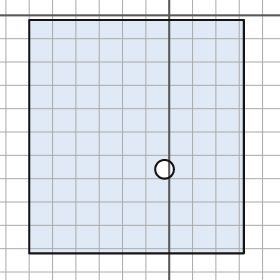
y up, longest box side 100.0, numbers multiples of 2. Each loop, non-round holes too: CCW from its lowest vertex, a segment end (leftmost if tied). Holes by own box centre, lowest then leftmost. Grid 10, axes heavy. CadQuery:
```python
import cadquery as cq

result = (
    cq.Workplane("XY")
    .moveTo(-60.0, -102.0)
    .lineTo(32.0, -102.0)
    .lineTo(32.0, -2.0)
    .lineTo(-60.0, -2.0)
    .close()
    .moveTo(-2.0, -66.0)
    .circle(4.0)
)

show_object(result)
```